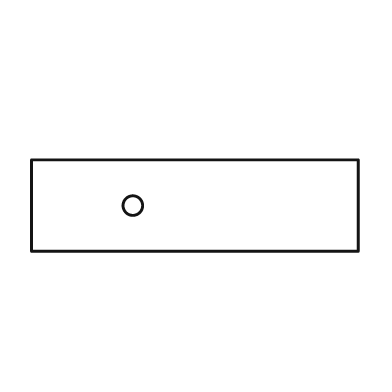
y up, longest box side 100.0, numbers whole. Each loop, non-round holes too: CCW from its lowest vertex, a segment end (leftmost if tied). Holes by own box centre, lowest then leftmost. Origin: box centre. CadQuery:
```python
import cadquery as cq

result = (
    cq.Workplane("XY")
    .moveTo(-50.0, -14.0)
    .lineTo(50.0, -14.0)
    .lineTo(50.0, 14.0)
    .lineTo(-50.0, 14.0)
    .close()
    .moveTo(-19.0, 0.0)
    .circle(3.0)
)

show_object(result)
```